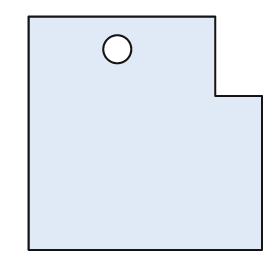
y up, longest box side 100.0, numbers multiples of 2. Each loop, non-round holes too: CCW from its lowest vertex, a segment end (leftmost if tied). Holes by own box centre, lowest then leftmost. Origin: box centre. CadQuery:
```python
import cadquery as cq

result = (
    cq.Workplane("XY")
    .moveTo(-50.0, -50.0)
    .lineTo(50.0, -50.0)
    .lineTo(50.0, 16.0)
    .lineTo(30.0, 16.0)
    .lineTo(30.0, 50.0)
    .lineTo(-50.0, 50.0)
    .close()
    .moveTo(-12.0, 36.0)
    .circle(6.0)
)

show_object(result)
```